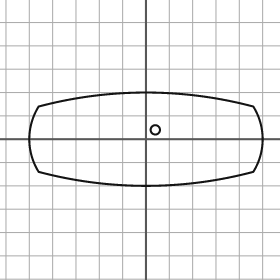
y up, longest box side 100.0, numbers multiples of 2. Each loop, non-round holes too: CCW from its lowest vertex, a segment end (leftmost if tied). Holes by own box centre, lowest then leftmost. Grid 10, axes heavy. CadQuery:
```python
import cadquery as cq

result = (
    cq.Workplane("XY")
    .moveTo(-46.0, -14.0)
    .threePointArc((0.0, -20.0), (46.0, -14.0))
    .threePointArc((50.0, 0.0), (46.0, 14.0))
    .threePointArc((0.0, 20.0), (-46.0, 14.0))
    .threePointArc((-50.0, 0.0), (-46.0, -14.0))
    .close()
    .moveTo(4.0, 4.0)
    .circle(2.0)
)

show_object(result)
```